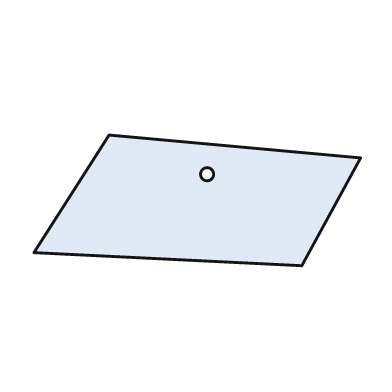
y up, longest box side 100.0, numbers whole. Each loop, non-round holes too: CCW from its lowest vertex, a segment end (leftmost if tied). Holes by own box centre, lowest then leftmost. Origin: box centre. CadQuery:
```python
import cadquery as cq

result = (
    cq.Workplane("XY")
    .moveTo(32.0, -20.0)
    .lineTo(50.0, 13.0)
    .lineTo(-27.0, 20.0)
    .lineTo(-50.0, -16.0)
    .close()
    .moveTo(3.0, 8.0)
    .circle(2.0)
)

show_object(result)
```